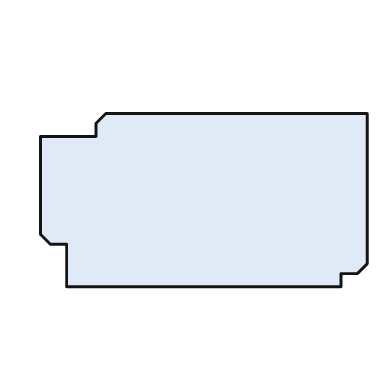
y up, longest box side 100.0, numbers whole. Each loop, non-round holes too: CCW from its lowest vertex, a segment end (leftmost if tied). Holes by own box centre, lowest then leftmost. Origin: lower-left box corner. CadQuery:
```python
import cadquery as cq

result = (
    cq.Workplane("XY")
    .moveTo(8.0, 0.0)
    .lineTo(92.0, 0.0)
    .lineTo(92.0, 4.0)
    .lineTo(97.0, 4.0)
    .lineTo(100.0, 7.0)
    .lineTo(100.0, 53.0)
    .lineTo(20.0, 53.0)
    .lineTo(17.0, 50.0)
    .lineTo(17.0, 46.0)
    .lineTo(0.0, 46.0)
    .lineTo(0.0, 16.0)
    .lineTo(3.0, 13.0)
    .lineTo(8.0, 13.0)
    .close()
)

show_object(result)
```